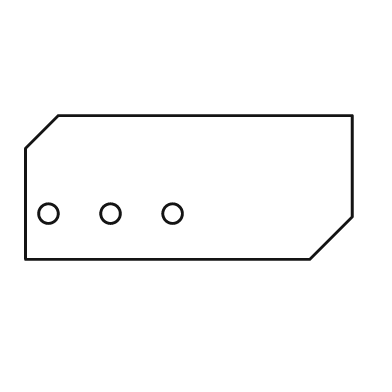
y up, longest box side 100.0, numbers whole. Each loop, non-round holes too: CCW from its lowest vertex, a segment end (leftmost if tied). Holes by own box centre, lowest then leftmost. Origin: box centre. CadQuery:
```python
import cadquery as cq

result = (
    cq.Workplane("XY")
    .moveTo(-50.0, -22.0)
    .lineTo(37.0, -22.0)
    .lineTo(50.0, -9.0)
    .lineTo(50.0, 22.0)
    .lineTo(-40.0, 22.0)
    .lineTo(-50.0, 12.0)
    .close()
    .moveTo(-43.0, -8.0)
    .circle(3.0)
    .moveTo(-24.0, -8.0)
    .circle(3.0)
    .moveTo(-5.0, -8.0)
    .circle(3.0)
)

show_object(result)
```